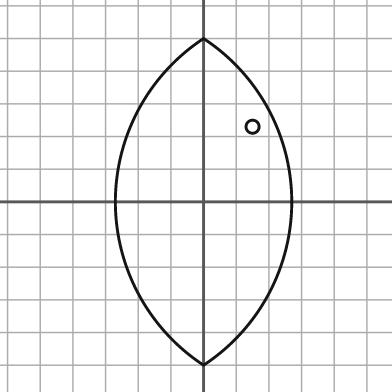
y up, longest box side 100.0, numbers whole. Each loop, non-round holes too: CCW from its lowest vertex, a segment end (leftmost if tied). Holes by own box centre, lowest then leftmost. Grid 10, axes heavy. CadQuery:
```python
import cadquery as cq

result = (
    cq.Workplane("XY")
    .moveTo(0.0, -50.0)
    .threePointArc((27.0, 0.0), (0.0, 50.0))
    .threePointArc((-27.0, 0.0), (0.0, -50.0))
    .close()
    .moveTo(15.0, 23.0)
    .circle(2.0)
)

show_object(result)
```